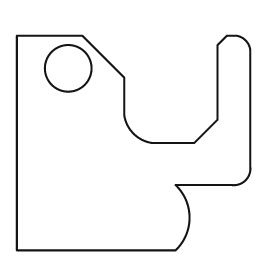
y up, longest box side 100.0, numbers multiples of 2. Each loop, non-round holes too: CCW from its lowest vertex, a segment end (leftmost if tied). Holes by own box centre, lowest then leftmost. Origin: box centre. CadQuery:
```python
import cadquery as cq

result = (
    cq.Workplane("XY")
    .moveTo(-50.0, -46.0)
    .lineTo(18.0, -46.0)
    .threePointArc((24.0, -32.0), (18.0, -18.0))
    .lineTo(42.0, -18.0)
    .threePointArc((48.0, -16.0), (50.0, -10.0))
    .lineTo(50.0, 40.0)
    .threePointArc((48.0, 44.0), (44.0, 46.0))
    .lineTo(40.0, 46.0)
    .lineTo(36.0, 42.0)
    .lineTo(36.0, 10.0)
    .lineTo(26.0, 0.0)
    .lineTo(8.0, 0.0)
    .threePointArc((0.0, 4.0), (-4.0, 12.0))
    .lineTo(-4.0, 28.0)
    .lineTo(-22.0, 46.0)
    .lineTo(-50.0, 46.0)
    .close()
    .moveTo(-28.0, 32.0)
    .circle(10.0)
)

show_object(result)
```